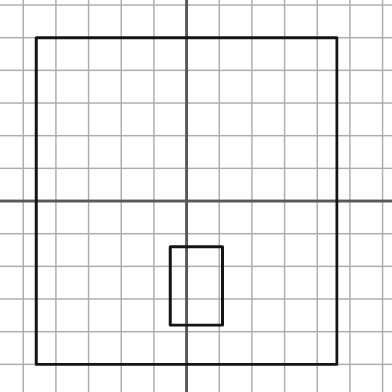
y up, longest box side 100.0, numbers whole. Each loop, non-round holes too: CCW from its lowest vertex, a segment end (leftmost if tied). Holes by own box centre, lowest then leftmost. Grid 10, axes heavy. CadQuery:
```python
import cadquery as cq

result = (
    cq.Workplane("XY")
    .moveTo(-46.0, -50.0)
    .lineTo(46.0, -50.0)
    .lineTo(46.0, 50.0)
    .lineTo(-46.0, 50.0)
    .close()
    .moveTo(-5.0, -38.0)
    .lineTo(11.0, -38.0)
    .lineTo(11.0, -14.0)
    .lineTo(-5.0, -14.0)
    .close()
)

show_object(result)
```